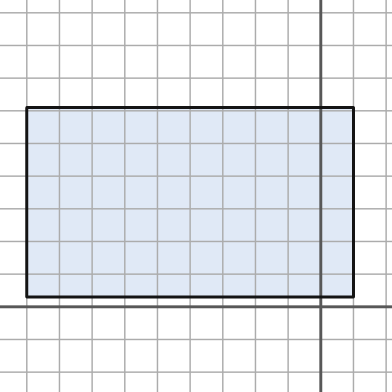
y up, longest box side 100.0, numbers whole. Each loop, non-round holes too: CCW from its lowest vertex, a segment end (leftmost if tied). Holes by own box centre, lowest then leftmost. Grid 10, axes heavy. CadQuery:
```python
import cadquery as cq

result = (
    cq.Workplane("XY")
    .moveTo(-90.0, 3.0)
    .lineTo(10.0, 3.0)
    .lineTo(10.0, 61.0)
    .lineTo(-90.0, 61.0)
    .close()
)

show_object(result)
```